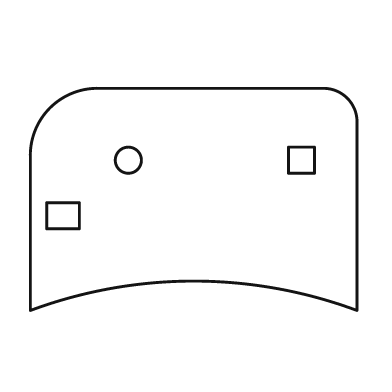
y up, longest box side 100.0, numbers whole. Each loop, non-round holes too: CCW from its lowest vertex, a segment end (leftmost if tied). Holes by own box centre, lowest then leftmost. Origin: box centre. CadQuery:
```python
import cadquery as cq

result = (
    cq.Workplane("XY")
    .moveTo(-50.0, -34.0)
    .threePointArc((0.0, -25.0), (50.0, -34.0))
    .lineTo(50.0, 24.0)
    .threePointArc((47.0, 31.0), (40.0, 34.0))
    .lineTo(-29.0, 34.0)
    .threePointArc((-44.0, 28.0), (-50.0, 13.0))
    .close()
    .moveTo(-45.0, -9.0)
    .lineTo(-35.0, -9.0)
    .lineTo(-35.0, -1.0)
    .lineTo(-45.0, -1.0)
    .close()
    .moveTo(-20.0, 12.0)
    .circle(4.0)
    .moveTo(29.0, 8.0)
    .lineTo(37.0, 8.0)
    .lineTo(37.0, 16.0)
    .lineTo(29.0, 16.0)
    .close()
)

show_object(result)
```